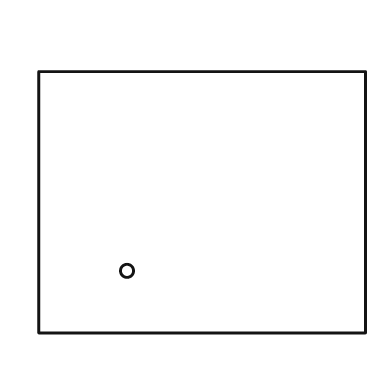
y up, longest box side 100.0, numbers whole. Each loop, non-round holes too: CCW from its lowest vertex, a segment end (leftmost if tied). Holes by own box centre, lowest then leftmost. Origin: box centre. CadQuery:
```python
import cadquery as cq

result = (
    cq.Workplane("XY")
    .moveTo(-50.0, -40.0)
    .lineTo(50.0, -40.0)
    .lineTo(50.0, 40.0)
    .lineTo(-50.0, 40.0)
    .close()
    .moveTo(-23.0, -21.0)
    .circle(2.0)
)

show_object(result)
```